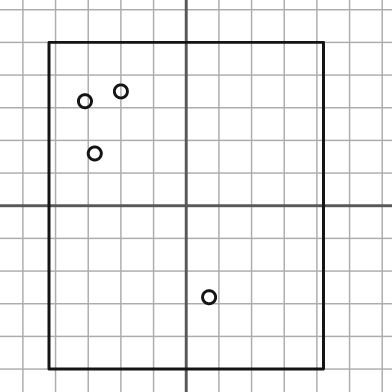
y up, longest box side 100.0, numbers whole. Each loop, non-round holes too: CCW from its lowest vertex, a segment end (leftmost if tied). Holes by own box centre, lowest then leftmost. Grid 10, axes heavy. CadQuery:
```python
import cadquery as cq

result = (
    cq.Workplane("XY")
    .moveTo(-42.0, -50.0)
    .lineTo(42.0, -50.0)
    .lineTo(42.0, 50.0)
    .lineTo(-42.0, 50.0)
    .close()
    .moveTo(7.0, -28.0)
    .circle(2.0)
    .moveTo(-28.0, 16.0)
    .circle(2.0)
    .moveTo(-31.0, 32.0)
    .circle(2.0)
    .moveTo(-20.0, 35.0)
    .circle(2.0)
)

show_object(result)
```